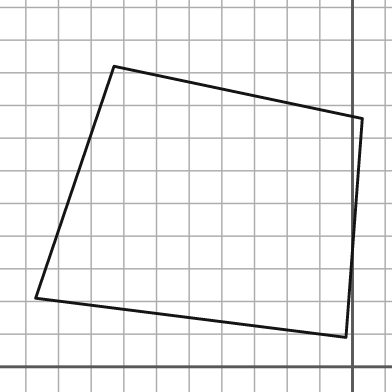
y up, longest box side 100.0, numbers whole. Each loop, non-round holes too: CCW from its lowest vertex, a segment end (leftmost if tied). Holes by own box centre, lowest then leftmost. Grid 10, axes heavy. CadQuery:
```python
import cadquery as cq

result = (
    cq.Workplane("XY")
    .moveTo(-2.0, 9.0)
    .lineTo(3.0, 76.0)
    .lineTo(-73.0, 92.0)
    .lineTo(-97.0, 21.0)
    .close()
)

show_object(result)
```